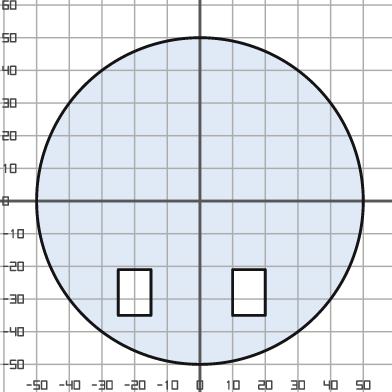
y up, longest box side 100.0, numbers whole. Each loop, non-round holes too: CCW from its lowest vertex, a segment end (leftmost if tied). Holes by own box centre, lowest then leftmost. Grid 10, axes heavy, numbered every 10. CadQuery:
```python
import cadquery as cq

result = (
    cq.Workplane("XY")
    .moveTo(0.0, 0.0)
    .circle(50.0)
    .moveTo(-25.0, -35.0)
    .lineTo(-15.0, -35.0)
    .lineTo(-15.0, -21.0)
    .lineTo(-25.0, -21.0)
    .close()
    .moveTo(10.0, -35.0)
    .lineTo(20.0, -35.0)
    .lineTo(20.0, -21.0)
    .lineTo(10.0, -21.0)
    .close()
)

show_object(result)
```